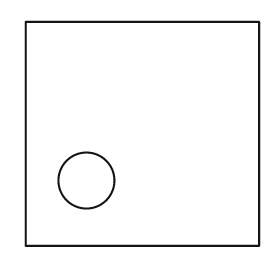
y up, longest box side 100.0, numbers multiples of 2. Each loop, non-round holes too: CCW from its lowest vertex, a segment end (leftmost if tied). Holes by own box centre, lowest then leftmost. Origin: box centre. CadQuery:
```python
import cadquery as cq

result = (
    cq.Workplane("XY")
    .moveTo(-50.0, -48.0)
    .lineTo(50.0, -48.0)
    .lineTo(50.0, 48.0)
    .lineTo(-50.0, 48.0)
    .close()
    .moveTo(-24.0, -20.0)
    .circle(12.0)
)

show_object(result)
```